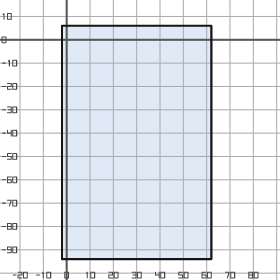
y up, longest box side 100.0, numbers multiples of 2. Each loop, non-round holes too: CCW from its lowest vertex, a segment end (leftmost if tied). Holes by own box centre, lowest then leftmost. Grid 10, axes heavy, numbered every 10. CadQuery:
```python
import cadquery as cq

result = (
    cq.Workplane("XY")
    .moveTo(-2.0, -94.0)
    .lineTo(62.0, -94.0)
    .lineTo(62.0, 6.0)
    .lineTo(-2.0, 6.0)
    .close()
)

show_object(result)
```